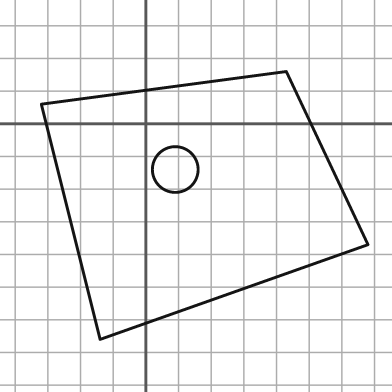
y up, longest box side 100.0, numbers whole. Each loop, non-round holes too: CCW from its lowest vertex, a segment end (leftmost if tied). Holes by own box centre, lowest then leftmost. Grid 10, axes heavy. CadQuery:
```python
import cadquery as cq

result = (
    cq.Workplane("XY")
    .moveTo(-14.0, -66.0)
    .lineTo(68.0, -37.0)
    .lineTo(43.0, 16.0)
    .lineTo(-32.0, 6.0)
    .close()
    .moveTo(9.0, -14.0)
    .circle(7.0)
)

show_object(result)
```